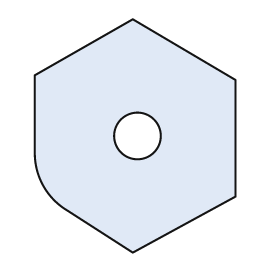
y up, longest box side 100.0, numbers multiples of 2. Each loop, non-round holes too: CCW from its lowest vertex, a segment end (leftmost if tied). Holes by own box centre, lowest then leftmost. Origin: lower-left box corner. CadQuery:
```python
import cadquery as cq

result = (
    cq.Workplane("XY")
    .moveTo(42.0, 0.0)
    .lineTo(86.0, 24.0)
    .lineTo(86.0, 74.0)
    .lineTo(42.0, 100.0)
    .lineTo(0.0, 76.0)
    .lineTo(0.0, 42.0)
    .threePointArc((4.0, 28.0), (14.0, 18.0))
    .close()
    .moveTo(44.0, 50.0)
    .circle(10.0)
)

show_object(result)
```